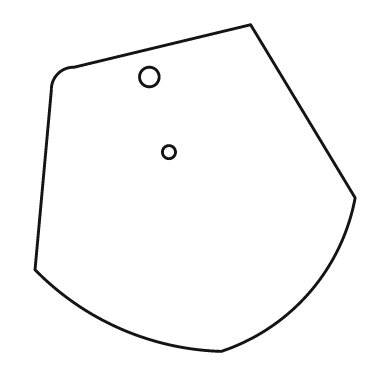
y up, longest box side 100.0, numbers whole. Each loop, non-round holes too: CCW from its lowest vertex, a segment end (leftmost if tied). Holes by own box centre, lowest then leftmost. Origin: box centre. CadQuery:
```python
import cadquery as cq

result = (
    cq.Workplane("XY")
    .moveTo(8.0, -50.0)
    .threePointArc((35.0, -32.0), (49.0, -3.0))
    .lineTo(17.0, 50.0)
    .lineTo(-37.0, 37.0)
    .threePointArc((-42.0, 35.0), (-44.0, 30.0))
    .lineTo(-49.0, -25.0)
    .threePointArc((-23.0, -43.0), (8.0, -50.0))
    .close()
    .moveTo(-8.0, 11.0)
    .circle(2.0)
    .moveTo(-14.0, 34.0)
    .circle(3.0)
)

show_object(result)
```